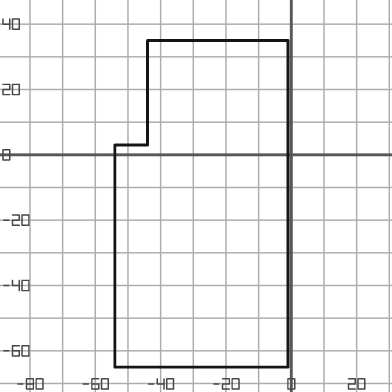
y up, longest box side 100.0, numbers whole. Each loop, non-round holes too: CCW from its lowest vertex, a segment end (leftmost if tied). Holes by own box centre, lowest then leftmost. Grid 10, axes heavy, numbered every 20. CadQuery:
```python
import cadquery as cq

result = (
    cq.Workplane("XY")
    .moveTo(-54.0, -65.0)
    .lineTo(-1.0, -65.0)
    .lineTo(-1.0, 35.0)
    .lineTo(-44.0, 35.0)
    .lineTo(-44.0, 3.0)
    .lineTo(-54.0, 3.0)
    .close()
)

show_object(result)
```